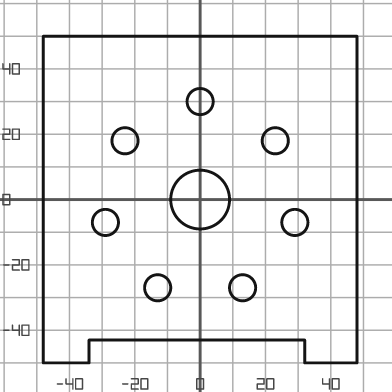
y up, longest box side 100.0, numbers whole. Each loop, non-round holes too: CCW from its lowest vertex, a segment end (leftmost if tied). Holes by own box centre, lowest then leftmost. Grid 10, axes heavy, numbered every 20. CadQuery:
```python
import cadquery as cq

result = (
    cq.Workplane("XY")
    .moveTo(-48.0, -50.0)
    .lineTo(-34.0, -50.0)
    .lineTo(-34.0, -43.0)
    .lineTo(32.0, -43.0)
    .lineTo(32.0, -50.0)
    .lineTo(48.0, -50.0)
    .lineTo(48.0, 50.0)
    .lineTo(-48.0, 50.0)
    .close()
    .moveTo(-13.0, -27.0)
    .circle(4.0)
    .moveTo(13.0, -27.0)
    .circle(4.0)
    .moveTo(-29.0, -7.0)
    .circle(4.0)
    .moveTo(29.0, -7.0)
    .circle(4.0)
    .moveTo(0.0, 0.0)
    .circle(9.0)
    .moveTo(-23.0, 18.0)
    .circle(4.0)
    .moveTo(23.0, 18.0)
    .circle(4.0)
    .moveTo(0.0, 30.0)
    .circle(4.0)
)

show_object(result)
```